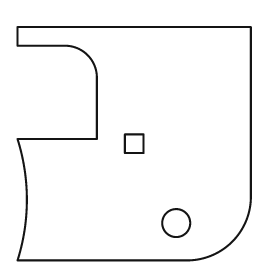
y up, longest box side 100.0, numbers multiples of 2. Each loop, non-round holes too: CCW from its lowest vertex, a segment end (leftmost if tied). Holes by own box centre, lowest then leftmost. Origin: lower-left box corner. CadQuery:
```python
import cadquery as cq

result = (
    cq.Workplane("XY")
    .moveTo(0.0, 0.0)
    .lineTo(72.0, 0.0)
    .threePointArc((92.0, 8.0), (100.0, 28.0))
    .lineTo(100.0, 100.0)
    .lineTo(0.0, 100.0)
    .lineTo(0.0, 92.0)
    .lineTo(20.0, 92.0)
    .threePointArc((30.0, 88.0), (34.0, 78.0))
    .lineTo(34.0, 52.0)
    .lineTo(0.0, 52.0)
    .threePointArc((4.0, 26.0), (0.0, 0.0))
    .close()
    .moveTo(68.0, 16.0)
    .circle(6.0)
    .moveTo(46.0, 46.0)
    .lineTo(54.0, 46.0)
    .lineTo(54.0, 54.0)
    .lineTo(46.0, 54.0)
    .close()
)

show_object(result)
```